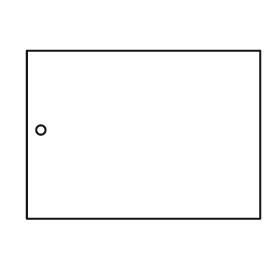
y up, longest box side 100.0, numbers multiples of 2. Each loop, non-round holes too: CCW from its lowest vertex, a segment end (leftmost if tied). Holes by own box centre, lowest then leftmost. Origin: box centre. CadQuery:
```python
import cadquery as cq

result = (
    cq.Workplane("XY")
    .moveTo(-50.0, -36.0)
    .lineTo(50.0, -36.0)
    .lineTo(50.0, 36.0)
    .lineTo(-50.0, 36.0)
    .close()
    .moveTo(-44.0, 2.0)
    .circle(2.0)
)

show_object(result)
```